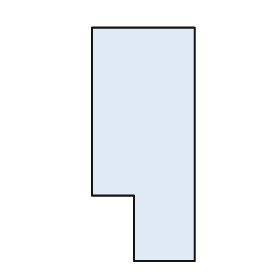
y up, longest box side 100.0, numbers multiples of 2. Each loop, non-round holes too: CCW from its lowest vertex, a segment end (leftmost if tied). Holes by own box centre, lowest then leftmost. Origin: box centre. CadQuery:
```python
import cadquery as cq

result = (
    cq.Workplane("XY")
    .moveTo(-4.0, -50.0)
    .lineTo(22.0, -50.0)
    .lineTo(22.0, 50.0)
    .lineTo(-22.0, 50.0)
    .lineTo(-22.0, -22.0)
    .lineTo(-4.0, -22.0)
    .close()
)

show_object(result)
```